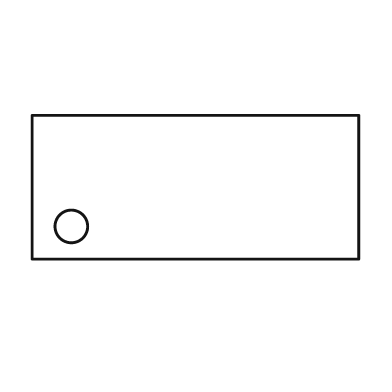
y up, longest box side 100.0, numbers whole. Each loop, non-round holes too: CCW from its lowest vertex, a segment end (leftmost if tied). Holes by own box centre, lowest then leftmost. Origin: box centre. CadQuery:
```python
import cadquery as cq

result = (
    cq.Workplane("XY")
    .moveTo(-50.0, -22.0)
    .lineTo(50.0, -22.0)
    .lineTo(50.0, 22.0)
    .lineTo(-50.0, 22.0)
    .close()
    .moveTo(-38.0, -12.0)
    .circle(5.0)
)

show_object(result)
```